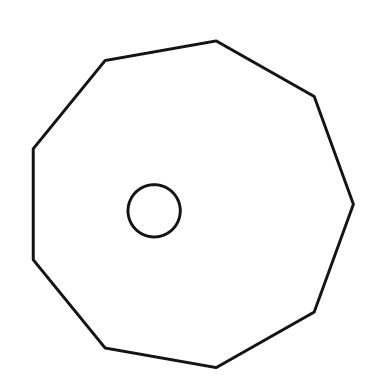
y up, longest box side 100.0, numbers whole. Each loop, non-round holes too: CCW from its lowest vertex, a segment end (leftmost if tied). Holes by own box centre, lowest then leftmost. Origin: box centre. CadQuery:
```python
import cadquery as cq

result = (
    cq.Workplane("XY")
    .moveTo(7.0, -50.0)
    .lineTo(37.0, -33.0)
    .lineTo(49.0, 0.0)
    .lineTo(37.0, 33.0)
    .lineTo(7.0, 50.0)
    .lineTo(-27.0, 44.0)
    .lineTo(-49.0, 17.0)
    .lineTo(-49.0, -17.0)
    .lineTo(-27.0, -44.0)
    .close()
    .moveTo(-12.0, -2.0)
    .circle(8.0)
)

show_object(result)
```